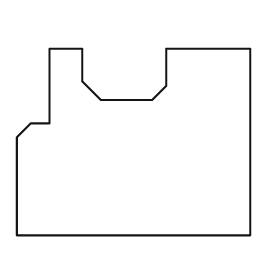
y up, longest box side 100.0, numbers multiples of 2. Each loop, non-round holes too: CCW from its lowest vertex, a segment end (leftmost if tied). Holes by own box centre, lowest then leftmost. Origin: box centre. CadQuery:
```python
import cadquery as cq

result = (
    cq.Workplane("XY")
    .moveTo(-50.0, -40.0)
    .lineTo(50.0, -40.0)
    .lineTo(50.0, 40.0)
    .lineTo(14.0, 40.0)
    .lineTo(14.0, 24.0)
    .lineTo(8.0, 18.0)
    .lineTo(-14.0, 18.0)
    .lineTo(-22.0, 26.0)
    .lineTo(-22.0, 40.0)
    .lineTo(-36.0, 40.0)
    .lineTo(-36.0, 8.0)
    .lineTo(-44.0, 8.0)
    .lineTo(-50.0, 2.0)
    .close()
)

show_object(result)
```